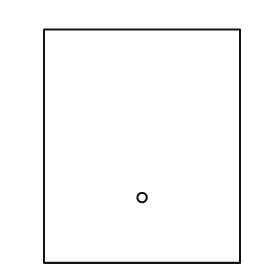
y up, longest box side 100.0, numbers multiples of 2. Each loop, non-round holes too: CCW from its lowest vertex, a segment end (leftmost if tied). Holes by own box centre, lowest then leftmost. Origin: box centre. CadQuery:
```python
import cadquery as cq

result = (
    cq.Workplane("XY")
    .moveTo(-42.0, -50.0)
    .lineTo(42.0, -50.0)
    .lineTo(42.0, 50.0)
    .lineTo(-42.0, 50.0)
    .close()
    .moveTo(0.0, -22.0)
    .circle(2.0)
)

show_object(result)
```